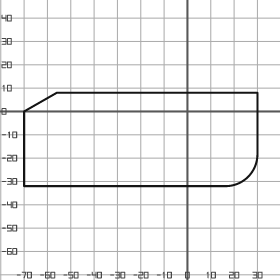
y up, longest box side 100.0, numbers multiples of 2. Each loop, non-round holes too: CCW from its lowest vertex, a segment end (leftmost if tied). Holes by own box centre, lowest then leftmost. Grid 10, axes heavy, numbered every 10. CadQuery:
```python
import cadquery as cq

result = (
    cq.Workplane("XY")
    .moveTo(-70.0, -32.0)
    .lineTo(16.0, -32.0)
    .threePointArc((26.0, -28.0), (30.0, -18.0))
    .lineTo(30.0, 8.0)
    .lineTo(-56.0, 8.0)
    .lineTo(-70.0, 0.0)
    .close()
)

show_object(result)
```